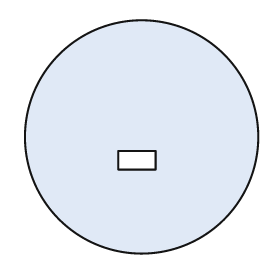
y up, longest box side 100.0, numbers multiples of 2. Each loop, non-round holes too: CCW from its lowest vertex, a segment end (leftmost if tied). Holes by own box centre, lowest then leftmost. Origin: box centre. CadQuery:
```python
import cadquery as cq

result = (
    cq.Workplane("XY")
    .moveTo(0.0, 0.0)
    .circle(50.0)
    .moveTo(-10.0, -14.0)
    .lineTo(6.0, -14.0)
    .lineTo(6.0, -6.0)
    .lineTo(-10.0, -6.0)
    .close()
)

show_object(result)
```